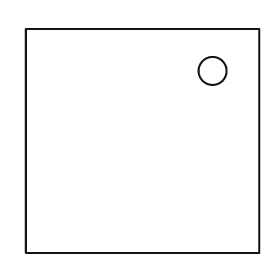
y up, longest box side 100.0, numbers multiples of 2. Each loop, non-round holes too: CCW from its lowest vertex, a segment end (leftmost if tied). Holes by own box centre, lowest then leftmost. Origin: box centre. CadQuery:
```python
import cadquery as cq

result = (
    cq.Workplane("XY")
    .moveTo(-50.0, -48.0)
    .lineTo(50.0, -48.0)
    .lineTo(50.0, 48.0)
    .lineTo(-50.0, 48.0)
    .close()
    .moveTo(30.0, 30.0)
    .circle(6.0)
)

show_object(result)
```